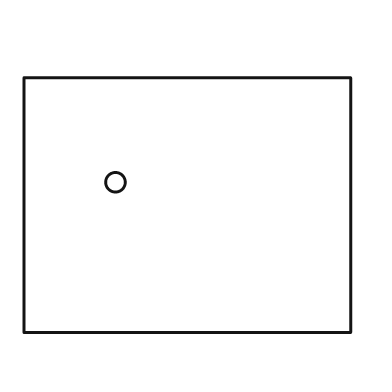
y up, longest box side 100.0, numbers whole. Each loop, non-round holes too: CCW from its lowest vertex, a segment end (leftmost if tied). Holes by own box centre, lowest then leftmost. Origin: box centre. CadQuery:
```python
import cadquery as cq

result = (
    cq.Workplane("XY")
    .moveTo(-50.0, -39.0)
    .lineTo(50.0, -39.0)
    .lineTo(50.0, 39.0)
    .lineTo(-50.0, 39.0)
    .close()
    .moveTo(-22.0, 7.0)
    .circle(3.0)
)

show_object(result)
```